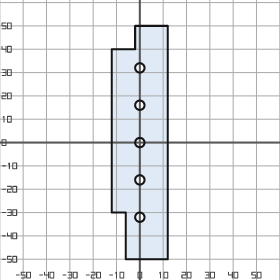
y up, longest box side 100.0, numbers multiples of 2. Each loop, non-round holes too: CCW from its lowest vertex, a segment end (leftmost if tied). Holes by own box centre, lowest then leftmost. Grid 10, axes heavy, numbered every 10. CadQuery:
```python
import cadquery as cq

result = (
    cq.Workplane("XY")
    .moveTo(-6.0, -50.0)
    .lineTo(12.0, -50.0)
    .lineTo(12.0, 50.0)
    .lineTo(-2.0, 50.0)
    .lineTo(-2.0, 40.0)
    .lineTo(-12.0, 40.0)
    .lineTo(-12.0, -30.0)
    .lineTo(-6.0, -30.0)
    .close()
    .moveTo(0.0, -32.0)
    .circle(2.0)
    .moveTo(0.0, -16.0)
    .circle(2.0)
    .moveTo(0.0, 0.0)
    .circle(2.0)
    .moveTo(0.0, 16.0)
    .circle(2.0)
    .moveTo(0.0, 32.0)
    .circle(2.0)
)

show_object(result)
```